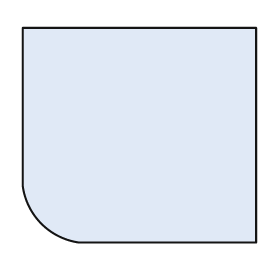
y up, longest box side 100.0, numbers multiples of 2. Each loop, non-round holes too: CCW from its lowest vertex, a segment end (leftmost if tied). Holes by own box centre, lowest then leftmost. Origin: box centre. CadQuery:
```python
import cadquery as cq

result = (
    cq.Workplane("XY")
    .moveTo(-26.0, -46.0)
    .lineTo(50.0, -46.0)
    .lineTo(50.0, 46.0)
    .lineTo(-50.0, 46.0)
    .lineTo(-50.0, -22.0)
    .threePointArc((-42.0, -38.0), (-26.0, -46.0))
    .close()
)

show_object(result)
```